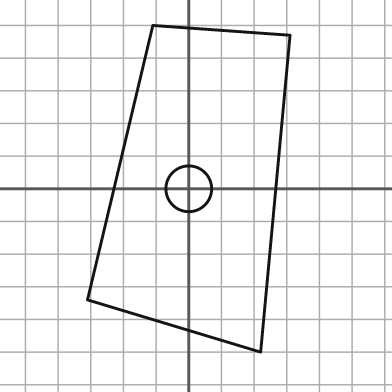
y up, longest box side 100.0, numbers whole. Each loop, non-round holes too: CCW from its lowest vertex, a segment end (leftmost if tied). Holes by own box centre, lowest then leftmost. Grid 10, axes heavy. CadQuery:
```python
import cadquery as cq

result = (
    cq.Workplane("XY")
    .moveTo(22.0, -50.0)
    .lineTo(31.0, 47.0)
    .lineTo(-11.0, 50.0)
    .lineTo(-31.0, -34.0)
    .close()
    .moveTo(0.0, 0.0)
    .circle(7.0)
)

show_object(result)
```